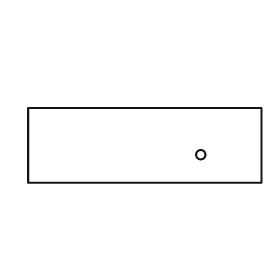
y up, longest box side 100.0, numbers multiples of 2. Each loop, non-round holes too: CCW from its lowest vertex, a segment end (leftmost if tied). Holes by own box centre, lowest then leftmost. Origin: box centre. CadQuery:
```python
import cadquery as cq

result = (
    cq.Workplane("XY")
    .moveTo(-50.0, -16.0)
    .lineTo(50.0, -16.0)
    .lineTo(50.0, 16.0)
    .lineTo(-50.0, 16.0)
    .close()
    .moveTo(24.0, -4.0)
    .circle(2.0)
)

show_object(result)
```